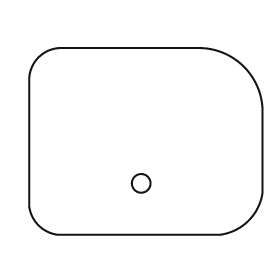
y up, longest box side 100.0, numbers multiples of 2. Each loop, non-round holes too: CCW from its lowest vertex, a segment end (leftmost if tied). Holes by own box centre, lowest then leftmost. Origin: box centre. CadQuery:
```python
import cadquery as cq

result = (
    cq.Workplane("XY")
    .moveTo(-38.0, -40.0)
    .lineTo(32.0, -40.0)
    .threePointArc((44.0, -34.0), (50.0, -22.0))
    .lineTo(50.0, 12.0)
    .threePointArc((42.0, 32.0), (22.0, 40.0))
    .lineTo(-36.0, 40.0)
    .threePointArc((-46.0, 36.0), (-50.0, 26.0))
    .lineTo(-50.0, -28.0)
    .threePointArc((-46.0, -36.0), (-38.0, -40.0))
    .close()
    .moveTo(-2.0, -18.0)
    .circle(4.0)
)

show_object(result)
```